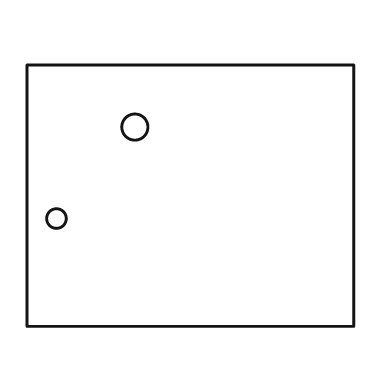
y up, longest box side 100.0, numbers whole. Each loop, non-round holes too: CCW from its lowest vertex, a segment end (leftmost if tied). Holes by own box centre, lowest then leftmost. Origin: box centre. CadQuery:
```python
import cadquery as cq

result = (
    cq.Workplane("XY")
    .moveTo(-50.0, -40.0)
    .lineTo(50.0, -40.0)
    .lineTo(50.0, 40.0)
    .lineTo(-50.0, 40.0)
    .close()
    .moveTo(-41.0, -7.0)
    .circle(3.0)
    .moveTo(-17.0, 21.0)
    .circle(4.0)
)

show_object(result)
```